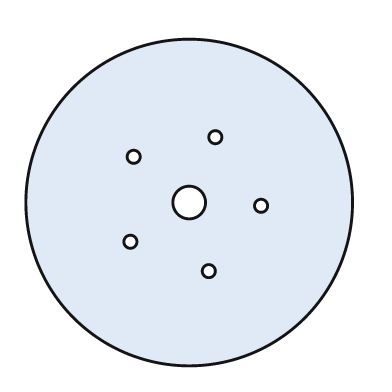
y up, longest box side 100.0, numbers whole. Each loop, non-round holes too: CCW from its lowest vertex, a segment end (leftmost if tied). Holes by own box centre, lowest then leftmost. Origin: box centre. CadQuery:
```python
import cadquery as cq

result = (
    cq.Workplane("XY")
    .moveTo(0.0, 0.0)
    .circle(50.0)
    .moveTo(6.0, -21.0)
    .circle(2.0)
    .moveTo(-18.0, -12.0)
    .circle(2.0)
    .moveTo(22.0, -1.0)
    .circle(2.0)
    .moveTo(0.0, 0.0)
    .circle(5.0)
    .moveTo(-17.0, 14.0)
    .circle(2.0)
    .moveTo(8.0, 20.0)
    .circle(2.0)
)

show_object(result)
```